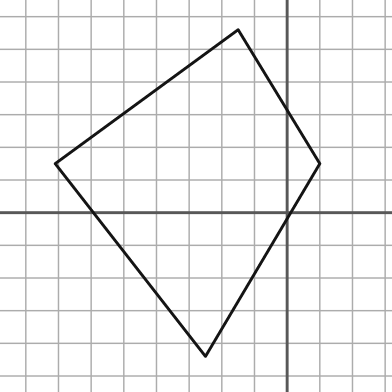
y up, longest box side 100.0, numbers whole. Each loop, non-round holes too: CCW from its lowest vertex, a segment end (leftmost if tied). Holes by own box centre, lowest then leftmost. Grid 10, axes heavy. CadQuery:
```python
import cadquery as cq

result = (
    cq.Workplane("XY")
    .moveTo(-25.0, -44.0)
    .lineTo(10.0, 15.0)
    .lineTo(-15.0, 56.0)
    .lineTo(-71.0, 15.0)
    .close()
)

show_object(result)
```